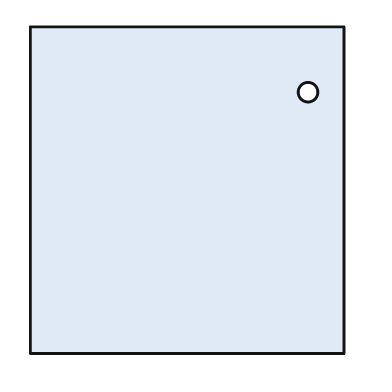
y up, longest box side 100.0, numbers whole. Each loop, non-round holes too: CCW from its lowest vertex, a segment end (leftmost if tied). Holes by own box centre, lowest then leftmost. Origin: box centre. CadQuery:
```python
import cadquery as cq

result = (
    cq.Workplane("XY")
    .moveTo(-48.0, -50.0)
    .lineTo(48.0, -50.0)
    .lineTo(48.0, 50.0)
    .lineTo(-48.0, 50.0)
    .close()
    .moveTo(37.0, 30.0)
    .circle(3.0)
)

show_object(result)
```